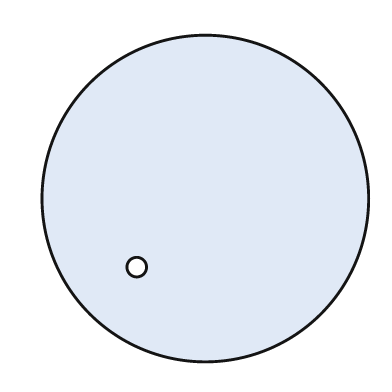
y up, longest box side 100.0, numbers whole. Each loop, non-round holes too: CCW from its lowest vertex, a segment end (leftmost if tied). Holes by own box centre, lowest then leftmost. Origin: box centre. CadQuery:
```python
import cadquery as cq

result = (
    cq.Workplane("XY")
    .moveTo(0.0, 0.0)
    .circle(50.0)
    .moveTo(-21.0, -21.0)
    .circle(3.0)
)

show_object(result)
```